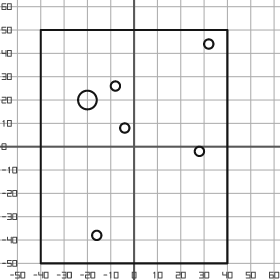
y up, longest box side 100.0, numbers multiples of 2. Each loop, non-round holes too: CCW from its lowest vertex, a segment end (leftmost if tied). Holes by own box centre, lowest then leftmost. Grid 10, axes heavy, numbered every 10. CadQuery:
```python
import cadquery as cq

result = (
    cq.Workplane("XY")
    .moveTo(-40.0, -50.0)
    .lineTo(40.0, -50.0)
    .lineTo(40.0, 50.0)
    .lineTo(-40.0, 50.0)
    .close()
    .moveTo(-16.0, -38.0)
    .circle(2.0)
    .moveTo(28.0, -2.0)
    .circle(2.0)
    .moveTo(-4.0, 8.0)
    .circle(2.0)
    .moveTo(-20.0, 20.0)
    .circle(4.0)
    .moveTo(-8.0, 26.0)
    .circle(2.0)
    .moveTo(32.0, 44.0)
    .circle(2.0)
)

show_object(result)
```